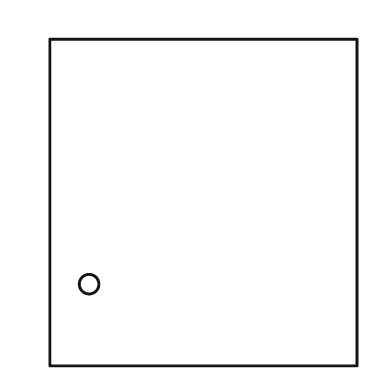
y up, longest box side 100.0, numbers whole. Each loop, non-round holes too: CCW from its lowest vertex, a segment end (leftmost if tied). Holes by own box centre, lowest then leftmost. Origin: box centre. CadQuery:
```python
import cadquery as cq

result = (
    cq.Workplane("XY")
    .moveTo(-47.0, -50.0)
    .lineTo(47.0, -50.0)
    .lineTo(47.0, 50.0)
    .lineTo(-47.0, 50.0)
    .close()
    .moveTo(-35.0, -25.0)
    .circle(3.0)
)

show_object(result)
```